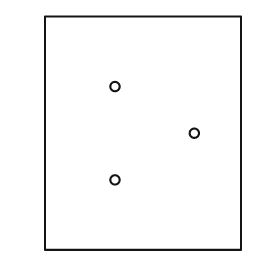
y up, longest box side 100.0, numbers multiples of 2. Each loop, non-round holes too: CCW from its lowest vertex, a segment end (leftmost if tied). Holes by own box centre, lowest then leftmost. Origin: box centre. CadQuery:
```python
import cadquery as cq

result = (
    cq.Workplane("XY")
    .moveTo(-42.0, -50.0)
    .lineTo(42.0, -50.0)
    .lineTo(42.0, 50.0)
    .lineTo(-42.0, 50.0)
    .close()
    .moveTo(-12.0, -20.0)
    .circle(2.0)
    .moveTo(22.0, 0.0)
    .circle(2.0)
    .moveTo(-12.0, 20.0)
    .circle(2.0)
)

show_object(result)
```